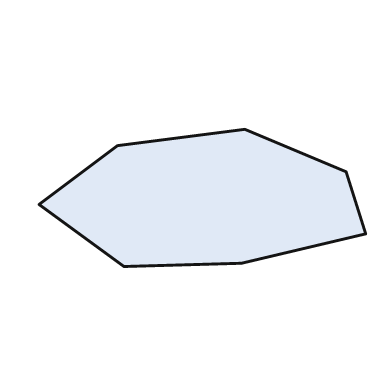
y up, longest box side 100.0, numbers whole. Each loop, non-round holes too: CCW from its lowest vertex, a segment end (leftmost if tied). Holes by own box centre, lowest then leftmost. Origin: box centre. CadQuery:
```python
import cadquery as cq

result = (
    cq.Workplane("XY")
    .moveTo(-24.0, -21.0)
    .lineTo(12.0, -20.0)
    .lineTo(50.0, -11.0)
    .lineTo(44.0, 8.0)
    .lineTo(13.0, 21.0)
    .lineTo(-26.0, 16.0)
    .lineTo(-50.0, -2.0)
    .close()
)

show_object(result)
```